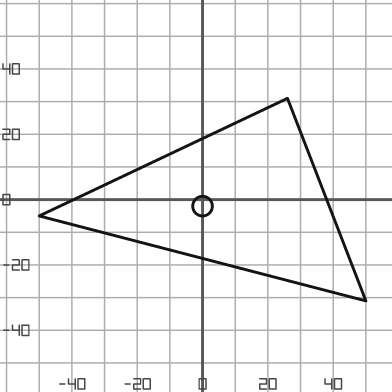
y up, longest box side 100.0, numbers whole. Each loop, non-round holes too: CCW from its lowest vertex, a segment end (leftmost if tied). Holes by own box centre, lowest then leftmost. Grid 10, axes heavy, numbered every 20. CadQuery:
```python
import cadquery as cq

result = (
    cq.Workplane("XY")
    .moveTo(50.0, -31.0)
    .lineTo(26.0, 31.0)
    .lineTo(-50.0, -5.0)
    .close()
    .moveTo(0.0, -2.0)
    .circle(3.0)
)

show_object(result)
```